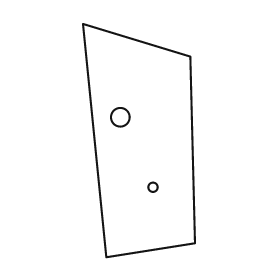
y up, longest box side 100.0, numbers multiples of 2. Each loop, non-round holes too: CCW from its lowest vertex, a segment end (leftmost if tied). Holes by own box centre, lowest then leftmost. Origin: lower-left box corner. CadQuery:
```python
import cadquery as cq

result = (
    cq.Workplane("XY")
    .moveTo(10.0, 0.0)
    .lineTo(48.0, 6.0)
    .lineTo(46.0, 86.0)
    .lineTo(0.0, 100.0)
    .close()
    .moveTo(30.0, 30.0)
    .circle(2.0)
    .moveTo(16.0, 60.0)
    .circle(4.0)
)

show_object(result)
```